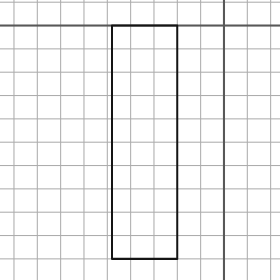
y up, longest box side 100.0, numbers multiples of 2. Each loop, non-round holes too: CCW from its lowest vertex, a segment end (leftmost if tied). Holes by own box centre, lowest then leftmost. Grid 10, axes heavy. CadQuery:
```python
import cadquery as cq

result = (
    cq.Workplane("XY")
    .moveTo(-48.0, -100.0)
    .lineTo(-20.0, -100.0)
    .lineTo(-20.0, 0.0)
    .lineTo(-48.0, 0.0)
    .close()
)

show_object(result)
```